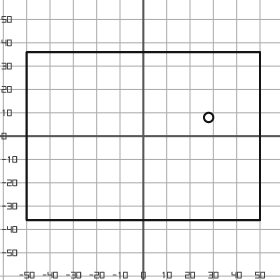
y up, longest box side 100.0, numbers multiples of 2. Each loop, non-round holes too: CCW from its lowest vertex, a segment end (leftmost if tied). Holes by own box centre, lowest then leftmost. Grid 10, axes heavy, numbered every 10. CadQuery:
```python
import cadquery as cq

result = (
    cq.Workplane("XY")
    .moveTo(-50.0, -36.0)
    .lineTo(50.0, -36.0)
    .lineTo(50.0, 36.0)
    .lineTo(-50.0, 36.0)
    .close()
    .moveTo(28.0, 8.0)
    .circle(2.0)
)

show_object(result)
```